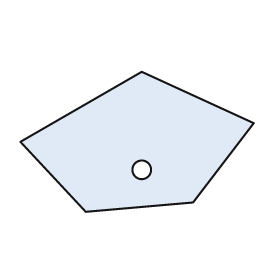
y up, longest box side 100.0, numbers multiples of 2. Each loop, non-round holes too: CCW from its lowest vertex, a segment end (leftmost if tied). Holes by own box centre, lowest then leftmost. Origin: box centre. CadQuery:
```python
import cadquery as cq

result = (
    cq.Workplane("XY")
    .moveTo(-22.0, -30.0)
    .lineTo(24.0, -26.0)
    .lineTo(50.0, 8.0)
    .lineTo(2.0, 30.0)
    .lineTo(-50.0, 0.0)
    .close()
    .moveTo(2.0, -12.0)
    .circle(4.0)
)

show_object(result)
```